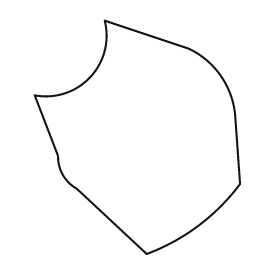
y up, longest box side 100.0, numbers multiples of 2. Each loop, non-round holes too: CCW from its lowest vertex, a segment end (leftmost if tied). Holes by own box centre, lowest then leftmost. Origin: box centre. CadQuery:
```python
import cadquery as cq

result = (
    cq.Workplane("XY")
    .moveTo(4.0, -50.0)
    .threePointArc((26.0, -38.0), (44.0, -20.0))
    .lineTo(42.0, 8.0)
    .threePointArc((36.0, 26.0), (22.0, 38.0))
    .lineTo(-14.0, 50.0)
    .threePointArc((-20.0, 26.0), (-44.0, 18.0))
    .lineTo(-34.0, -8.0)
    .threePointArc((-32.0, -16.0), (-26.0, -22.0))
    .close()
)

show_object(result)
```